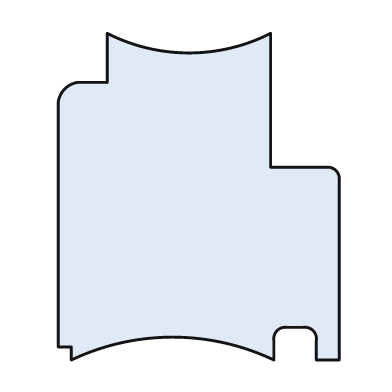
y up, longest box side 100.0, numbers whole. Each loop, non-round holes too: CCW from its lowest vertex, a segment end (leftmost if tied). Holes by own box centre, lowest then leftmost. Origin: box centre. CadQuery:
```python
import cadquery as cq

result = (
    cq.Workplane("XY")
    .moveTo(-39.0, -50.0)
    .threePointArc((-8.0, -43.0), (23.0, -50.0))
    .lineTo(23.0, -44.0)
    .threePointArc((24.0, -41.0), (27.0, -40.0))
    .lineTo(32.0, -40.0)
    .threePointArc((35.0, -41.0), (36.0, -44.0))
    .lineTo(36.0, -50.0)
    .lineTo(43.0, -50.0)
    .lineTo(43.0, 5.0)
    .threePointArc((42.0, 8.0), (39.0, 9.0))
    .lineTo(22.0, 9.0)
    .lineTo(22.0, 50.0)
    .threePointArc((-3.0, 44.0), (-28.0, 50.0))
    .lineTo(-28.0, 35.0)
    .lineTo(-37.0, 35.0)
    .threePointArc((-41.0, 33.0), (-43.0, 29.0))
    .lineTo(-43.0, -46.0)
    .lineTo(-39.0, -46.0)
    .close()
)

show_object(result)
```